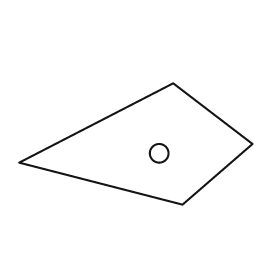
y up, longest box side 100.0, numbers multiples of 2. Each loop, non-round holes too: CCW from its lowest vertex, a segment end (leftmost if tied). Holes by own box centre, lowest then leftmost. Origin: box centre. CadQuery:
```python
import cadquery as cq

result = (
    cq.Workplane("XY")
    .moveTo(20.0, -26.0)
    .lineTo(50.0, 0.0)
    .lineTo(16.0, 26.0)
    .lineTo(-50.0, -8.0)
    .close()
    .moveTo(10.0, -4.0)
    .circle(4.0)
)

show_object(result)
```